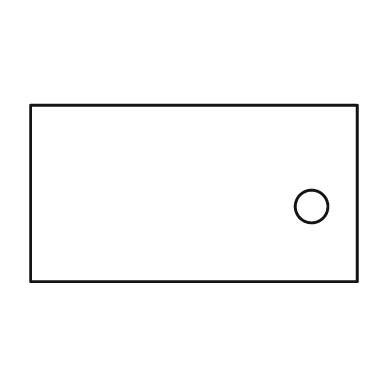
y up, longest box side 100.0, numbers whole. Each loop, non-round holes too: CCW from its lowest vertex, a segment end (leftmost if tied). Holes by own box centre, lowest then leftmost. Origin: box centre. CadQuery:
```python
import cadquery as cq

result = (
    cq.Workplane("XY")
    .moveTo(-50.0, -27.0)
    .lineTo(50.0, -27.0)
    .lineTo(50.0, 27.0)
    .lineTo(-50.0, 27.0)
    .close()
    .moveTo(36.0, -4.0)
    .circle(5.0)
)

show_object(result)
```